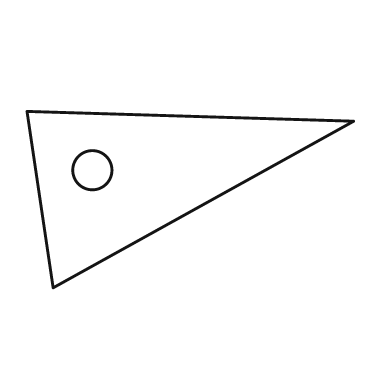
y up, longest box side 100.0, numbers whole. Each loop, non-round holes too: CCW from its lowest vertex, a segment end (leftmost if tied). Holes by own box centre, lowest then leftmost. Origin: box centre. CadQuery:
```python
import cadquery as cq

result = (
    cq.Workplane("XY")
    .moveTo(-42.0, -27.0)
    .lineTo(50.0, 24.0)
    .lineTo(-50.0, 27.0)
    .close()
    .moveTo(-30.0, 9.0)
    .circle(6.0)
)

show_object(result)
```